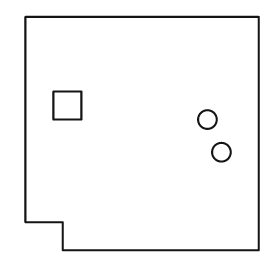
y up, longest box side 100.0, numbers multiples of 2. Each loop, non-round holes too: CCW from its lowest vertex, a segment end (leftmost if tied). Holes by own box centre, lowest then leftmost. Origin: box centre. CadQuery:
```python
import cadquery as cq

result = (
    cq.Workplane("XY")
    .moveTo(-34.0, -50.0)
    .lineTo(50.0, -50.0)
    .lineTo(50.0, 50.0)
    .lineTo(-50.0, 50.0)
    .lineTo(-50.0, -38.0)
    .lineTo(-34.0, -38.0)
    .close()
    .moveTo(34.0, -8.0)
    .circle(4.0)
    .moveTo(28.0, 6.0)
    .circle(4.0)
    .moveTo(-38.0, 6.0)
    .lineTo(-26.0, 6.0)
    .lineTo(-26.0, 18.0)
    .lineTo(-38.0, 18.0)
    .close()
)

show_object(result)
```